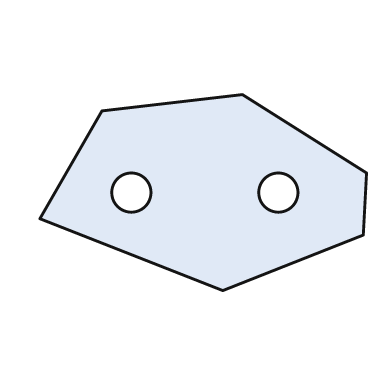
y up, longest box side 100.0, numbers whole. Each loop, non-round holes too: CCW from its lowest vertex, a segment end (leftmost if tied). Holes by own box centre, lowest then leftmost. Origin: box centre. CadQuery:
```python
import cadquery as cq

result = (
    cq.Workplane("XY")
    .moveTo(6.0, -30.0)
    .lineTo(49.0, -13.0)
    .lineTo(50.0, 6.0)
    .lineTo(12.0, 30.0)
    .lineTo(-31.0, 25.0)
    .lineTo(-50.0, -8.0)
    .close()
    .moveTo(-22.0, 0.0)
    .circle(6.0)
    .moveTo(23.0, 0.0)
    .circle(6.0)
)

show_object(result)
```